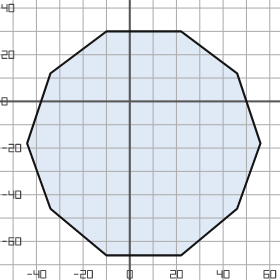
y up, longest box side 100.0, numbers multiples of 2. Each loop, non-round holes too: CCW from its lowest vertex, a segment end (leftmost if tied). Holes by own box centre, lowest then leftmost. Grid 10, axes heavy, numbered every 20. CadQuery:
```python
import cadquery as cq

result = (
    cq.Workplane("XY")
    .moveTo(-10.0, -66.0)
    .lineTo(22.0, -66.0)
    .lineTo(46.0, -46.0)
    .lineTo(56.0, -18.0)
    .lineTo(46.0, 12.0)
    .lineTo(22.0, 30.0)
    .lineTo(-10.0, 30.0)
    .lineTo(-34.0, 12.0)
    .lineTo(-44.0, -18.0)
    .lineTo(-34.0, -46.0)
    .close()
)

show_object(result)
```